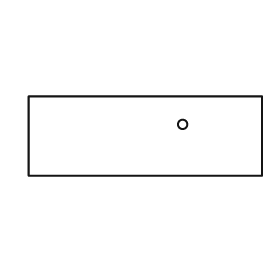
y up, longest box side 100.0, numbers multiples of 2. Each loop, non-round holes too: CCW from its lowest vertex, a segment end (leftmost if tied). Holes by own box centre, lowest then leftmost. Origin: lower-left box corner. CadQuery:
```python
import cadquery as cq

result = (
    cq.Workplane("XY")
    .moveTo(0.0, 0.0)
    .lineTo(100.0, 0.0)
    .lineTo(100.0, 34.0)
    .lineTo(0.0, 34.0)
    .close()
    .moveTo(66.0, 22.0)
    .circle(2.0)
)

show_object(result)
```